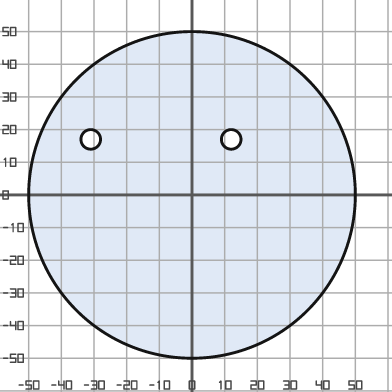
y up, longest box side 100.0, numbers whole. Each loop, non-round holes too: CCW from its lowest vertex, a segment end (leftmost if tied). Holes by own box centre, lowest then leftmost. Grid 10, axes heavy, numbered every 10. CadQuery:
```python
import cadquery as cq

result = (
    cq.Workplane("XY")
    .moveTo(0.0, 0.0)
    .circle(50.0)
    .moveTo(-31.0, 17.0)
    .circle(3.0)
    .moveTo(12.0, 17.0)
    .circle(3.0)
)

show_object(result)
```